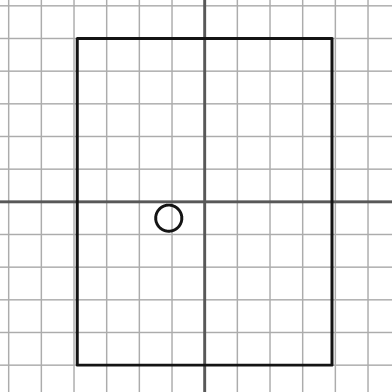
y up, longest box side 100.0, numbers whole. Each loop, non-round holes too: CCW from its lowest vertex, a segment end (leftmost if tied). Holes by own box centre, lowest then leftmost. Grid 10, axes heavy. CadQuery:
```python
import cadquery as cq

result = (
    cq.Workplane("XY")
    .moveTo(-39.0, -50.0)
    .lineTo(39.0, -50.0)
    .lineTo(39.0, 50.0)
    .lineTo(-39.0, 50.0)
    .close()
    .moveTo(-11.0, -5.0)
    .circle(4.0)
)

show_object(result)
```